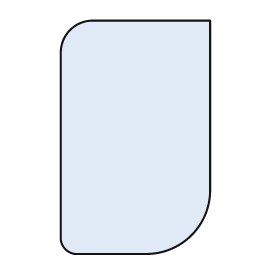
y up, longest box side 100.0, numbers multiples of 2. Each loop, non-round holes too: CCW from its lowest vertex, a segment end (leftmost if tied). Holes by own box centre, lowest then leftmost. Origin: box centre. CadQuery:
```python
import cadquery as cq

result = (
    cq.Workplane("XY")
    .moveTo(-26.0, -50.0)
    .lineTo(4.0, -50.0)
    .threePointArc((24.0, -42.0), (32.0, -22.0))
    .lineTo(32.0, 50.0)
    .lineTo(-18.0, 50.0)
    .threePointArc((-28.0, 46.0), (-32.0, 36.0))
    .lineTo(-32.0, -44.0)
    .threePointArc((-30.0, -48.0), (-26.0, -50.0))
    .close()
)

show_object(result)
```